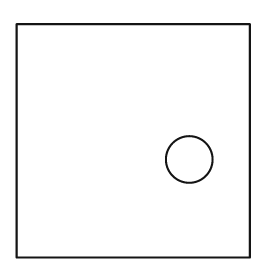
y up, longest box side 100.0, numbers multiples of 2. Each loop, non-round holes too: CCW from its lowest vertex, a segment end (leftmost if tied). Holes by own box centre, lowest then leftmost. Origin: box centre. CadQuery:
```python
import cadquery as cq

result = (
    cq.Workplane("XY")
    .moveTo(-50.0, -50.0)
    .lineTo(50.0, -50.0)
    .lineTo(50.0, 50.0)
    .lineTo(-50.0, 50.0)
    .close()
    .moveTo(24.0, -8.0)
    .circle(10.0)
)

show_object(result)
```